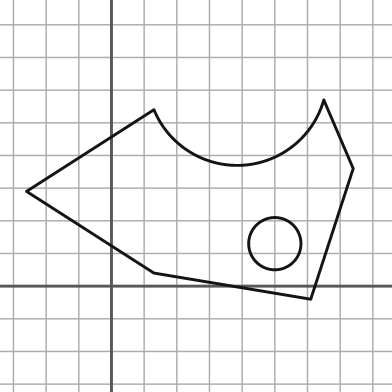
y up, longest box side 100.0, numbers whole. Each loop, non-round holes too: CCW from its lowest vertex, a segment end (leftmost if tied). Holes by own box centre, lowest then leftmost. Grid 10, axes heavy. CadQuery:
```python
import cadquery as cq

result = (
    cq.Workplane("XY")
    .moveTo(61.0, -4.0)
    .lineTo(74.0, 36.0)
    .lineTo(65.0, 57.0)
    .threePointArc((40.0, 37.0), (13.0, 54.0))
    .lineTo(-26.0, 29.0)
    .lineTo(13.0, 4.0)
    .close()
    .moveTo(50.0, 13.0)
    .circle(8.0)
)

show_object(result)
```